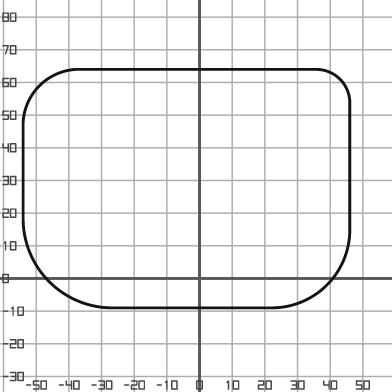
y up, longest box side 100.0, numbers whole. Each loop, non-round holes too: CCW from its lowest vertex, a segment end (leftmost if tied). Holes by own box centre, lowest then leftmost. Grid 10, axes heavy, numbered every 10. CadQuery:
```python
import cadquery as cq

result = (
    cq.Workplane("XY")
    .moveTo(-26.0, -9.0)
    .lineTo(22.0, -9.0)
    .threePointArc((39.0, -2.0), (46.0, 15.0))
    .lineTo(46.0, 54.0)
    .threePointArc((43.0, 61.0), (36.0, 64.0))
    .lineTo(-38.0, 64.0)
    .threePointArc((-49.0, 59.0), (-54.0, 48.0))
    .lineTo(-54.0, 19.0)
    .threePointArc((-46.0, -1.0), (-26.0, -9.0))
    .close()
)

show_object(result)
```